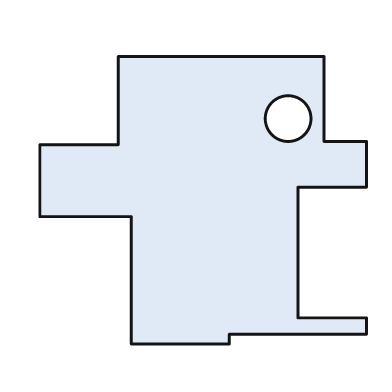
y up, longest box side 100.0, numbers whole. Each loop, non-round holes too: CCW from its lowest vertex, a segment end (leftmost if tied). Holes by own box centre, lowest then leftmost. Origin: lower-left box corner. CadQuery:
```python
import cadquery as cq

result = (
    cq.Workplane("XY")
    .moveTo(28.0, 0.0)
    .lineTo(58.0, 0.0)
    .lineTo(58.0, 3.0)
    .lineTo(100.0, 3.0)
    .lineTo(100.0, 8.0)
    .lineTo(79.0, 8.0)
    .lineTo(79.0, 48.0)
    .lineTo(100.0, 48.0)
    .lineTo(100.0, 62.0)
    .lineTo(87.0, 62.0)
    .lineTo(87.0, 88.0)
    .lineTo(24.0, 88.0)
    .lineTo(24.0, 61.0)
    .lineTo(0.0, 61.0)
    .lineTo(0.0, 39.0)
    .lineTo(28.0, 39.0)
    .close()
    .moveTo(76.0, 69.0)
    .circle(7.0)
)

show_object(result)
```